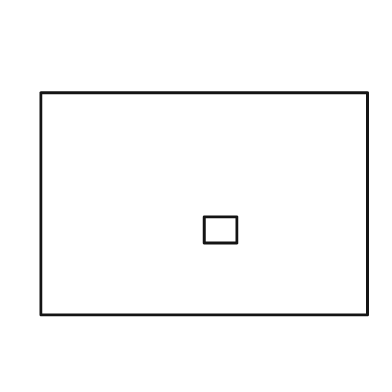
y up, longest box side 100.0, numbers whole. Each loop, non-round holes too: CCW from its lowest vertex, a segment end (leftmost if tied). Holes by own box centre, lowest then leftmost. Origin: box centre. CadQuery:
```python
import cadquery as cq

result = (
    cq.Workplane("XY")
    .moveTo(-50.0, -34.0)
    .lineTo(50.0, -34.0)
    .lineTo(50.0, 34.0)
    .lineTo(-50.0, 34.0)
    .close()
    .moveTo(0.0, -12.0)
    .lineTo(10.0, -12.0)
    .lineTo(10.0, -4.0)
    .lineTo(0.0, -4.0)
    .close()
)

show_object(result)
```